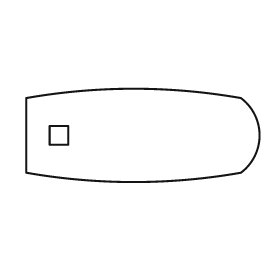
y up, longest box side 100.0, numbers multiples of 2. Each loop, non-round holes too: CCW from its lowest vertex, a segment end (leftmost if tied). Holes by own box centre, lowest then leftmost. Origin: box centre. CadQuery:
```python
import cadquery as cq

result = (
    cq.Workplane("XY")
    .moveTo(-50.0, -16.0)
    .threePointArc((-4.0, -20.0), (42.0, -16.0))
    .threePointArc((50.0, 0.0), (42.0, 16.0))
    .threePointArc((-4.0, 20.0), (-50.0, 16.0))
    .close()
    .moveTo(-40.0, -4.0)
    .lineTo(-32.0, -4.0)
    .lineTo(-32.0, 4.0)
    .lineTo(-40.0, 4.0)
    .close()
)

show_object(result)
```